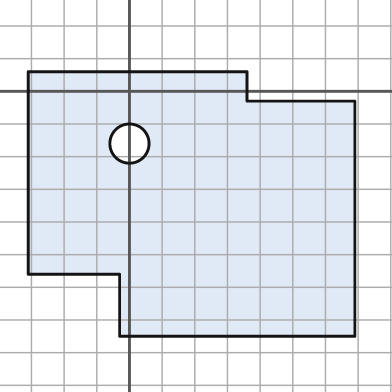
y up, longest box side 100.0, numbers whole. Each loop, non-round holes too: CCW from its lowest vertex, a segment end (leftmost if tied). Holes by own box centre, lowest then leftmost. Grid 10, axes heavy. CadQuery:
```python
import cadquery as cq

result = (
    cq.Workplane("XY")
    .moveTo(-3.0, -75.0)
    .lineTo(69.0, -75.0)
    .lineTo(69.0, -3.0)
    .lineTo(36.0, -3.0)
    .lineTo(36.0, 6.0)
    .lineTo(-31.0, 6.0)
    .lineTo(-31.0, -56.0)
    .lineTo(-3.0, -56.0)
    .close()
    .moveTo(0.0, -16.0)
    .circle(6.0)
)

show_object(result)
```